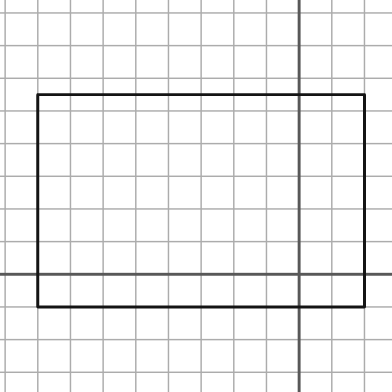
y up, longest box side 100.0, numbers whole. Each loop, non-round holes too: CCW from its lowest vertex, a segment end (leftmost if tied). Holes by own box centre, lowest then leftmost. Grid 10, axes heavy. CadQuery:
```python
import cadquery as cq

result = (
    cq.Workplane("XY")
    .moveTo(-80.0, -10.0)
    .lineTo(20.0, -10.0)
    .lineTo(20.0, 55.0)
    .lineTo(-80.0, 55.0)
    .close()
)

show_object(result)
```